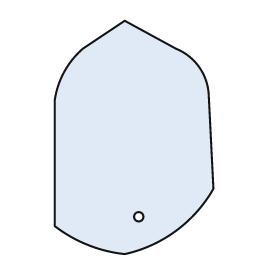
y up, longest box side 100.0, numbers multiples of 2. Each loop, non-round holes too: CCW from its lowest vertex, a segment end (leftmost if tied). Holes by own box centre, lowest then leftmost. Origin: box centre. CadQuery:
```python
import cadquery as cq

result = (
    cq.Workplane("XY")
    .moveTo(-4.0, -50.0)
    .threePointArc((18.0, -40.0), (34.0, -22.0))
    .lineTo(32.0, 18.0)
    .threePointArc((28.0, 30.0), (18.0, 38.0))
    .lineTo(-4.0, 50.0)
    .lineTo(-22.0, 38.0)
    .threePointArc((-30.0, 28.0), (-34.0, 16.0))
    .lineTo(-34.0, -38.0)
    .threePointArc((-20.0, -46.0), (-4.0, -50.0))
    .close()
    .moveTo(2.0, -34.0)
    .circle(2.0)
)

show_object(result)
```